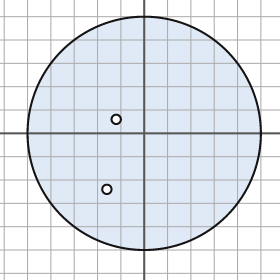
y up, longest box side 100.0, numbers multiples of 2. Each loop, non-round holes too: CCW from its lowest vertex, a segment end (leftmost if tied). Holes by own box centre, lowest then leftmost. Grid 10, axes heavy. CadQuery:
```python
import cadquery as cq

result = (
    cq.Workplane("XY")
    .moveTo(0.0, 0.0)
    .circle(50.0)
    .moveTo(-16.0, -24.0)
    .circle(2.0)
    .moveTo(-12.0, 6.0)
    .circle(2.0)
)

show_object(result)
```